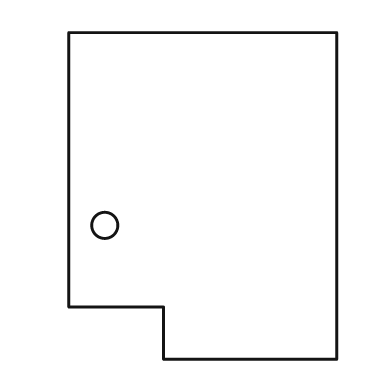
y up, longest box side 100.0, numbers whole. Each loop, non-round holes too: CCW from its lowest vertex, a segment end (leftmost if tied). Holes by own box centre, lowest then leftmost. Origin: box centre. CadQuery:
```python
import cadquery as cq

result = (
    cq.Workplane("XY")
    .moveTo(-12.0, -50.0)
    .lineTo(41.0, -50.0)
    .lineTo(41.0, 50.0)
    .lineTo(-41.0, 50.0)
    .lineTo(-41.0, -34.0)
    .lineTo(-12.0, -34.0)
    .close()
    .moveTo(-30.0, -9.0)
    .circle(4.0)
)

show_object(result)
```